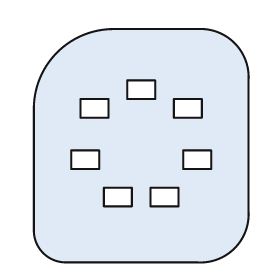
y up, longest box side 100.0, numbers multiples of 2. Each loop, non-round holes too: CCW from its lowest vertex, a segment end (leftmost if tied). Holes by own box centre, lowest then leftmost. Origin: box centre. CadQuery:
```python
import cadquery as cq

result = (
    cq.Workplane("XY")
    .moveTo(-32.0, -50.0)
    .lineTo(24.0, -50.0)
    .threePointArc((40.0, -44.0), (46.0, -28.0))
    .lineTo(46.0, 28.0)
    .threePointArc((40.0, 44.0), (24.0, 50.0))
    .lineTo(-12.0, 50.0)
    .threePointArc((-36.0, 40.0), (-46.0, 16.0))
    .lineTo(-46.0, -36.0)
    .threePointArc((-42.0, -46.0), (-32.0, -50.0))
    .close()
    .moveTo(-16.0, -26.0)
    .lineTo(-4.0, -26.0)
    .lineTo(-4.0, -18.0)
    .lineTo(-16.0, -18.0)
    .close()
    .moveTo(4.0, -26.0)
    .lineTo(16.0, -26.0)
    .lineTo(16.0, -18.0)
    .lineTo(4.0, -18.0)
    .close()
    .moveTo(-30.0, -10.0)
    .lineTo(-18.0, -10.0)
    .lineTo(-18.0, -2.0)
    .lineTo(-30.0, -2.0)
    .close()
    .moveTo(18.0, -10.0)
    .lineTo(30.0, -10.0)
    .lineTo(30.0, -2.0)
    .lineTo(18.0, -2.0)
    .close()
    .moveTo(-26.0, 12.0)
    .lineTo(-14.0, 12.0)
    .lineTo(-14.0, 20.0)
    .lineTo(-26.0, 20.0)
    .close()
    .moveTo(14.0, 12.0)
    .lineTo(26.0, 12.0)
    .lineTo(26.0, 20.0)
    .lineTo(14.0, 20.0)
    .close()
    .moveTo(-6.0, 20.0)
    .lineTo(6.0, 20.0)
    .lineTo(6.0, 28.0)
    .lineTo(-6.0, 28.0)
    .close()
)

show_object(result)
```